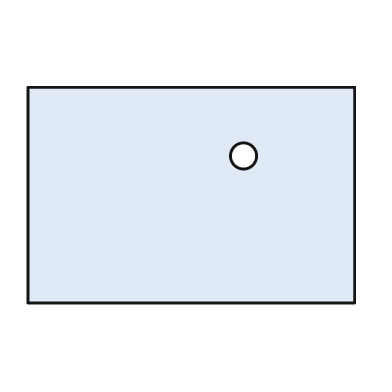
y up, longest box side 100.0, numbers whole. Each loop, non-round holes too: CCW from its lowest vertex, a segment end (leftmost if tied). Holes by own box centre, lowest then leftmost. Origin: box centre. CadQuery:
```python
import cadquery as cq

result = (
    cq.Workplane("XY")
    .moveTo(-50.0, -33.0)
    .lineTo(50.0, -33.0)
    .lineTo(50.0, 33.0)
    .lineTo(-50.0, 33.0)
    .close()
    .moveTo(16.0, 12.0)
    .circle(4.0)
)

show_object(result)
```